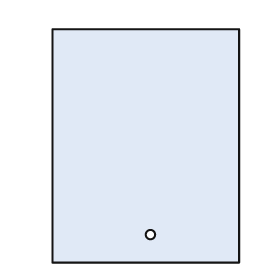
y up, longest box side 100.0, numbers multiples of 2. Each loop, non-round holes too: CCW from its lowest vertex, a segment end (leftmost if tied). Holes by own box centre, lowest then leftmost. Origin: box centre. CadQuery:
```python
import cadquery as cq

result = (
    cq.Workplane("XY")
    .moveTo(-40.0, -50.0)
    .lineTo(40.0, -50.0)
    .lineTo(40.0, 50.0)
    .lineTo(-40.0, 50.0)
    .close()
    .moveTo(2.0, -38.0)
    .circle(2.0)
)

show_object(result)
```